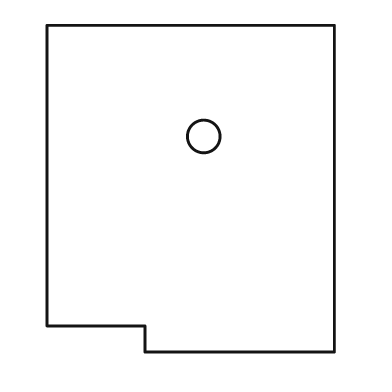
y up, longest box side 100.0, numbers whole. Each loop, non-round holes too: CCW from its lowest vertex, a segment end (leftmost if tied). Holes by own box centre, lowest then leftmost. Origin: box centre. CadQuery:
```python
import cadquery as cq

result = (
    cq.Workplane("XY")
    .moveTo(-14.0, -50.0)
    .lineTo(44.0, -50.0)
    .lineTo(44.0, 50.0)
    .lineTo(-44.0, 50.0)
    .lineTo(-44.0, -42.0)
    .lineTo(-14.0, -42.0)
    .close()
    .moveTo(4.0, 16.0)
    .circle(5.0)
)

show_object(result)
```